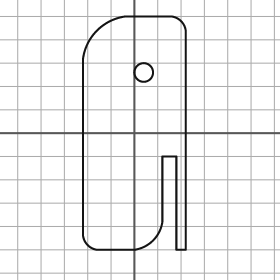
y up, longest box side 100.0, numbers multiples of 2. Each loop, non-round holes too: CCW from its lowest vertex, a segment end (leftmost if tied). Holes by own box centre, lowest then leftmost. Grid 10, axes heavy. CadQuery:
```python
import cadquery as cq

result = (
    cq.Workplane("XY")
    .moveTo(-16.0, -50.0)
    .lineTo(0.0, -50.0)
    .threePointArc((8.0, -46.0), (12.0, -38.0))
    .lineTo(12.0, -10.0)
    .lineTo(18.0, -10.0)
    .lineTo(18.0, -50.0)
    .lineTo(22.0, -50.0)
    .lineTo(22.0, 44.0)
    .threePointArc((20.0, 48.0), (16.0, 50.0))
    .lineTo(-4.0, 50.0)
    .threePointArc((-16.0, 44.0), (-22.0, 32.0))
    .lineTo(-22.0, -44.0)
    .threePointArc((-20.0, -48.0), (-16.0, -50.0))
    .close()
    .moveTo(4.0, 26.0)
    .circle(4.0)
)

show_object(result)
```